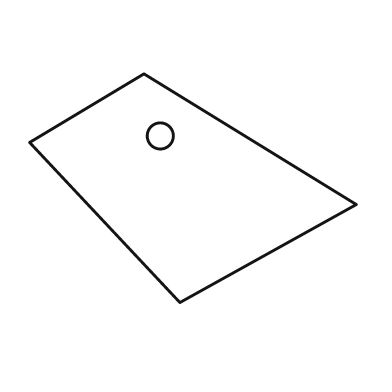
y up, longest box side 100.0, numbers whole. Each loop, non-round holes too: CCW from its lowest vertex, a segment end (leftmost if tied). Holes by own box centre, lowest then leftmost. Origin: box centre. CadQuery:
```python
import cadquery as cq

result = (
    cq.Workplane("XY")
    .moveTo(-4.0, -35.0)
    .lineTo(50.0, -5.0)
    .lineTo(-15.0, 35.0)
    .lineTo(-50.0, 14.0)
    .close()
    .moveTo(-10.0, 16.0)
    .circle(4.0)
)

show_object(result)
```